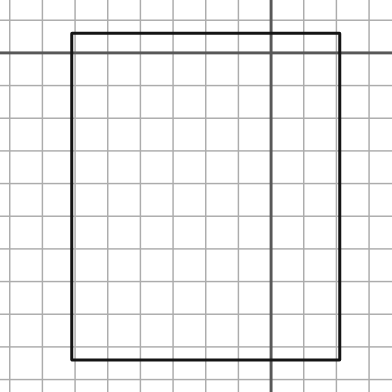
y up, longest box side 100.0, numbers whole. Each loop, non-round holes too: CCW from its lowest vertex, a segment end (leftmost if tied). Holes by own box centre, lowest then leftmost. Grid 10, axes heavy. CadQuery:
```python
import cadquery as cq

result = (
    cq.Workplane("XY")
    .moveTo(-61.0, -94.0)
    .lineTo(21.0, -94.0)
    .lineTo(21.0, 6.0)
    .lineTo(-61.0, 6.0)
    .close()
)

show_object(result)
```